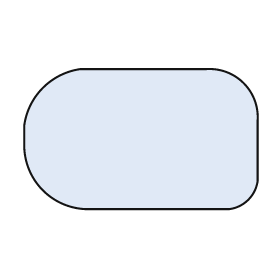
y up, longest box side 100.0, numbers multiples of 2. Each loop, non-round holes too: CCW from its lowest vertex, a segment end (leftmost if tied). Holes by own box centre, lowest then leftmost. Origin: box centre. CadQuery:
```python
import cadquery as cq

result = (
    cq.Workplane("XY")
    .moveTo(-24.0, -30.0)
    .lineTo(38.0, -30.0)
    .threePointArc((46.0, -26.0), (50.0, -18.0))
    .lineTo(50.0, 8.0)
    .threePointArc((44.0, 24.0), (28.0, 30.0))
    .lineTo(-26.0, 30.0)
    .threePointArc((-42.0, 22.0), (-50.0, 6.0))
    .lineTo(-50.0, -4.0)
    .threePointArc((-42.0, -22.0), (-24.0, -30.0))
    .close()
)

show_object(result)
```